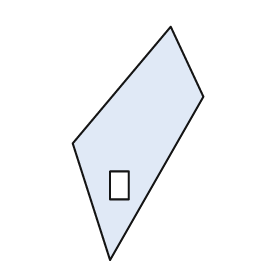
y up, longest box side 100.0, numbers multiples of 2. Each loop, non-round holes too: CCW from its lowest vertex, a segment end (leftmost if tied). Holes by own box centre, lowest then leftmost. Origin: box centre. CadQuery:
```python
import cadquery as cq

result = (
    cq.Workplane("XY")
    .moveTo(-12.0, -50.0)
    .lineTo(28.0, 20.0)
    .lineTo(14.0, 50.0)
    .lineTo(-28.0, 0.0)
    .close()
    .moveTo(-12.0, -24.0)
    .lineTo(-4.0, -24.0)
    .lineTo(-4.0, -12.0)
    .lineTo(-12.0, -12.0)
    .close()
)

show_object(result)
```